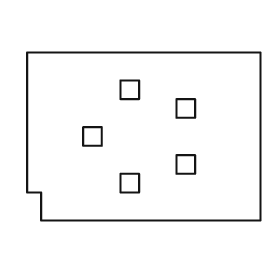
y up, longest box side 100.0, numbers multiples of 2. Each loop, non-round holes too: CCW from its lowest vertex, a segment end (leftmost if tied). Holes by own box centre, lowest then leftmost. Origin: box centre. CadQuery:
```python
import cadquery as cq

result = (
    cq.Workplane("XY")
    .moveTo(-44.0, -36.0)
    .lineTo(50.0, -36.0)
    .lineTo(50.0, 36.0)
    .lineTo(-50.0, 36.0)
    .lineTo(-50.0, -24.0)
    .lineTo(-44.0, -24.0)
    .close()
    .moveTo(-10.0, -24.0)
    .lineTo(-2.0, -24.0)
    .lineTo(-2.0, -16.0)
    .lineTo(-10.0, -16.0)
    .close()
    .moveTo(14.0, -16.0)
    .lineTo(22.0, -16.0)
    .lineTo(22.0, -8.0)
    .lineTo(14.0, -8.0)
    .close()
    .moveTo(-26.0, -4.0)
    .lineTo(-18.0, -4.0)
    .lineTo(-18.0, 4.0)
    .lineTo(-26.0, 4.0)
    .close()
    .moveTo(14.0, 8.0)
    .lineTo(22.0, 8.0)
    .lineTo(22.0, 16.0)
    .lineTo(14.0, 16.0)
    .close()
    .moveTo(-10.0, 16.0)
    .lineTo(-2.0, 16.0)
    .lineTo(-2.0, 24.0)
    .lineTo(-10.0, 24.0)
    .close()
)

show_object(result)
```